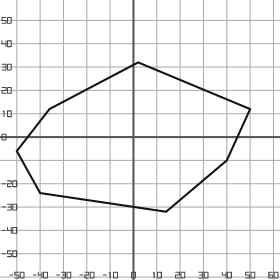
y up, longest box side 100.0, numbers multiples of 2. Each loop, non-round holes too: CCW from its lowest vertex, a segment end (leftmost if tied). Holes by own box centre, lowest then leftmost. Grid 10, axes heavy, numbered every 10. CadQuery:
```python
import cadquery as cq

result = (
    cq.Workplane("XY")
    .moveTo(14.0, -32.0)
    .lineTo(40.0, -10.0)
    .lineTo(50.0, 12.0)
    .lineTo(2.0, 32.0)
    .lineTo(-36.0, 12.0)
    .lineTo(-50.0, -6.0)
    .lineTo(-40.0, -24.0)
    .close()
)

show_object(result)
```